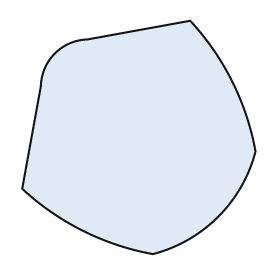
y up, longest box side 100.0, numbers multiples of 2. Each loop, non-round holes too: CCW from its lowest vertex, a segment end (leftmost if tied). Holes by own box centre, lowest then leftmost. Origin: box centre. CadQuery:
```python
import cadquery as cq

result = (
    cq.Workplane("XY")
    .moveTo(6.0, -50.0)
    .threePointArc((34.0, -34.0), (50.0, -6.0))
    .threePointArc((40.0, 24.0), (22.0, 50.0))
    .lineTo(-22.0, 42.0)
    .threePointArc((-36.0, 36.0), (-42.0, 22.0))
    .lineTo(-50.0, -22.0)
    .threePointArc((-24.0, -40.0), (6.0, -50.0))
    .close()
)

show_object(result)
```